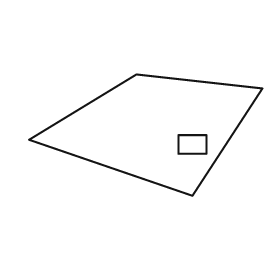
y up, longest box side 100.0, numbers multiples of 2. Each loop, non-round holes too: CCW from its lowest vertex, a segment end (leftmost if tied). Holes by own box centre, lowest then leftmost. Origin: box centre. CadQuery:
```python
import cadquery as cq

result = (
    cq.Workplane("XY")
    .moveTo(20.0, -26.0)
    .lineTo(50.0, 20.0)
    .lineTo(-4.0, 26.0)
    .lineTo(-50.0, -2.0)
    .close()
    .moveTo(14.0, -8.0)
    .lineTo(26.0, -8.0)
    .lineTo(26.0, 0.0)
    .lineTo(14.0, 0.0)
    .close()
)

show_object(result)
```